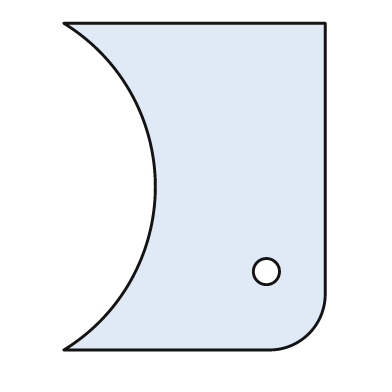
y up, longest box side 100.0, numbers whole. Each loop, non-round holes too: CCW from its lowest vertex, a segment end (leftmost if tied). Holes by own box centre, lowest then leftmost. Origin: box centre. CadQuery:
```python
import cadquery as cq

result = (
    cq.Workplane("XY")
    .moveTo(-40.0, -50.0)
    .lineTo(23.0, -50.0)
    .threePointArc((35.0, -45.0), (40.0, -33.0))
    .lineTo(40.0, 50.0)
    .lineTo(-40.0, 50.0)
    .threePointArc((-12.0, 0.0), (-40.0, -50.0))
    .close()
    .moveTo(22.0, -26.0)
    .circle(4.0)
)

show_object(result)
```